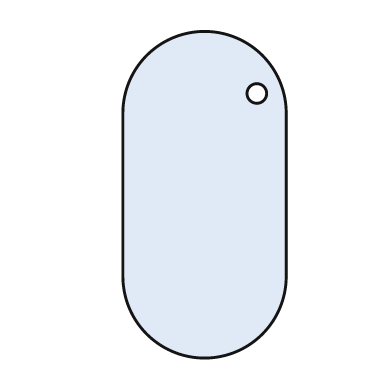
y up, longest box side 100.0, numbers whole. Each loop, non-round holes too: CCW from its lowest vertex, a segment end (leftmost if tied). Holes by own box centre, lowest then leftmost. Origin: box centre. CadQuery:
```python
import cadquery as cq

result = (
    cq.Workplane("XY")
    .moveTo(-25.0, -25.0)
    .threePointArc((0.0, -50.0), (25.0, -25.0))
    .lineTo(25.0, 25.0)
    .threePointArc((0.0, 50.0), (-25.0, 25.0))
    .close()
    .moveTo(16.0, 31.0)
    .circle(3.0)
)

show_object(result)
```